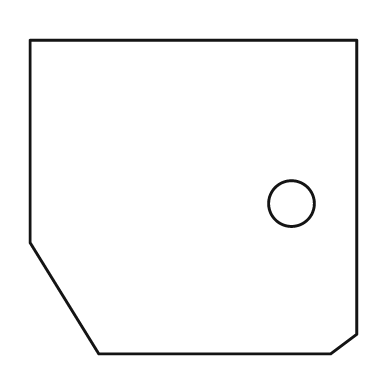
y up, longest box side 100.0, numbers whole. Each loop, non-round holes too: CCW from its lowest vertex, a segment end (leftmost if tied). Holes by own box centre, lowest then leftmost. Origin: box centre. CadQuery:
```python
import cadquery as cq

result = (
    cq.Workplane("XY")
    .moveTo(-29.0, -48.0)
    .lineTo(42.0, -48.0)
    .lineTo(50.0, -42.0)
    .lineTo(50.0, 48.0)
    .lineTo(-50.0, 48.0)
    .lineTo(-50.0, -14.0)
    .close()
    .moveTo(30.0, -2.0)
    .circle(7.0)
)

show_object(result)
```